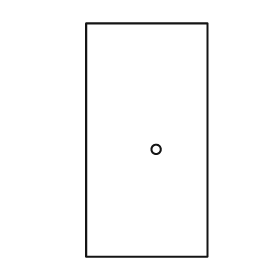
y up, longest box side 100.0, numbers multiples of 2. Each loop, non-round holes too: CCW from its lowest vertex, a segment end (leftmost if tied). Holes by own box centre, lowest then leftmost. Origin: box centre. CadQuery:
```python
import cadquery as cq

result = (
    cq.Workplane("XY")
    .moveTo(-26.0, -50.0)
    .lineTo(26.0, -50.0)
    .lineTo(26.0, 50.0)
    .lineTo(-26.0, 50.0)
    .close()
    .moveTo(4.0, -4.0)
    .circle(2.0)
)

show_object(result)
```